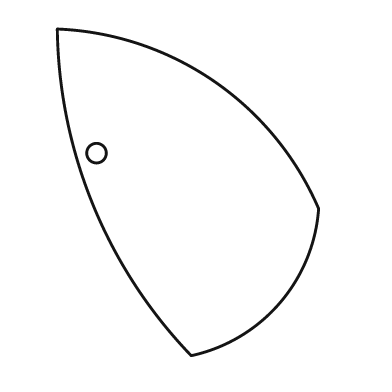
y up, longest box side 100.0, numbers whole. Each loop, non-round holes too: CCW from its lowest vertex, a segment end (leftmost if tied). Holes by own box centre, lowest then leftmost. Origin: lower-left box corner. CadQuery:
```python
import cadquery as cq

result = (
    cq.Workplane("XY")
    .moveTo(41.0, 0.0)
    .threePointArc((68.0, 16.0), (80.0, 45.0))
    .threePointArc((48.0, 84.0), (0.0, 100.0))
    .threePointArc((11.0, 46.0), (41.0, 0.0))
    .close()
    .moveTo(12.0, 62.0)
    .circle(3.0)
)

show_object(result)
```